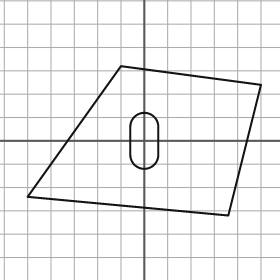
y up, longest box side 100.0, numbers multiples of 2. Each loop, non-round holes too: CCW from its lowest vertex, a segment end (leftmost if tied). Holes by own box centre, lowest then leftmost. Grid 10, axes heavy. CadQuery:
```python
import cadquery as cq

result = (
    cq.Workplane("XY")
    .moveTo(36.0, -32.0)
    .lineTo(50.0, 24.0)
    .lineTo(-10.0, 32.0)
    .lineTo(-50.0, -24.0)
    .close()
    .moveTo(-6.0, -6.0)
    .threePointArc((0.0, -12.0), (6.0, -6.0))
    .lineTo(6.0, 6.0)
    .threePointArc((0.0, 12.0), (-6.0, 6.0))
    .close()
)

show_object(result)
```